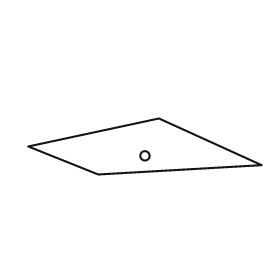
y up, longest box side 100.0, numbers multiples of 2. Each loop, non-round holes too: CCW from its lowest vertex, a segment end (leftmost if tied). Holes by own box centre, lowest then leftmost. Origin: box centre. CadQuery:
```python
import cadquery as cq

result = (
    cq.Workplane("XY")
    .moveTo(-20.0, -12.0)
    .lineTo(50.0, -8.0)
    .lineTo(6.0, 12.0)
    .lineTo(-50.0, 0.0)
    .close()
    .moveTo(0.0, -4.0)
    .circle(2.0)
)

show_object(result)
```